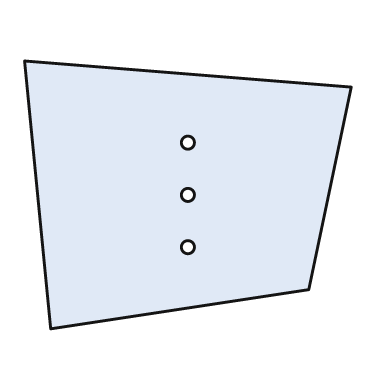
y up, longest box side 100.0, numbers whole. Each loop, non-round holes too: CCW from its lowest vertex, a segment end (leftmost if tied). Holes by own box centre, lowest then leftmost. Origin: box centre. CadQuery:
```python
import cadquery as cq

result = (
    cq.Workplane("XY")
    .moveTo(-42.0, -41.0)
    .lineTo(37.0, -29.0)
    .lineTo(50.0, 33.0)
    .lineTo(-50.0, 41.0)
    .close()
    .moveTo(0.0, -16.0)
    .circle(2.0)
    .moveTo(0.0, 0.0)
    .circle(2.0)
    .moveTo(0.0, 16.0)
    .circle(2.0)
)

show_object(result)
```